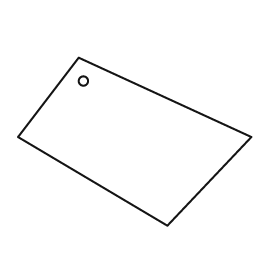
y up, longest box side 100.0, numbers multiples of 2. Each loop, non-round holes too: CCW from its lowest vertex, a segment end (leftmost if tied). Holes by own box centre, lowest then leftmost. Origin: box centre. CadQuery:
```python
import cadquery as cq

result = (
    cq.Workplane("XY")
    .moveTo(14.0, -36.0)
    .lineTo(50.0, 2.0)
    .lineTo(-24.0, 36.0)
    .lineTo(-50.0, 2.0)
    .close()
    .moveTo(-22.0, 26.0)
    .circle(2.0)
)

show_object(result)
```